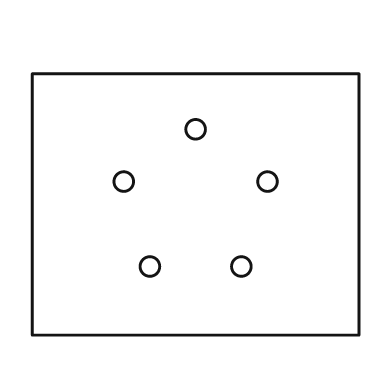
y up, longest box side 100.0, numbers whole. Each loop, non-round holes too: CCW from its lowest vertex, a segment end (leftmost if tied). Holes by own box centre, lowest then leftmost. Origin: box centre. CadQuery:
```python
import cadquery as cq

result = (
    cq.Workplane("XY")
    .moveTo(-50.0, -40.0)
    .lineTo(50.0, -40.0)
    .lineTo(50.0, 40.0)
    .lineTo(-50.0, 40.0)
    .close()
    .moveTo(-14.0, -19.0)
    .circle(3.0)
    .moveTo(14.0, -19.0)
    .circle(3.0)
    .moveTo(-22.0, 7.0)
    .circle(3.0)
    .moveTo(22.0, 7.0)
    .circle(3.0)
    .moveTo(0.0, 23.0)
    .circle(3.0)
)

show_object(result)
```